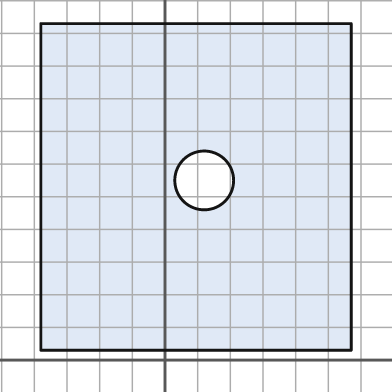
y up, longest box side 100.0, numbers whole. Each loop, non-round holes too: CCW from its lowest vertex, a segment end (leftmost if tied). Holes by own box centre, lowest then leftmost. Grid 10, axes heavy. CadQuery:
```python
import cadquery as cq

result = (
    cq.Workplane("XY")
    .moveTo(-38.0, 3.0)
    .lineTo(57.0, 3.0)
    .lineTo(57.0, 103.0)
    .lineTo(-38.0, 103.0)
    .close()
    .moveTo(12.0, 55.0)
    .circle(9.0)
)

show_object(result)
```